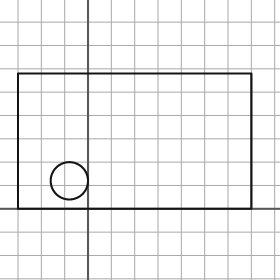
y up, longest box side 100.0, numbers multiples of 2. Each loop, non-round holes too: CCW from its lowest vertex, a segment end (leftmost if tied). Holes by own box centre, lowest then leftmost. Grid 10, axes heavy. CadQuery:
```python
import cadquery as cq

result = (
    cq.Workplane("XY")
    .moveTo(-30.0, 0.0)
    .lineTo(70.0, 0.0)
    .lineTo(70.0, 58.0)
    .lineTo(-30.0, 58.0)
    .close()
    .moveTo(-8.0, 12.0)
    .circle(8.0)
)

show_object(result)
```